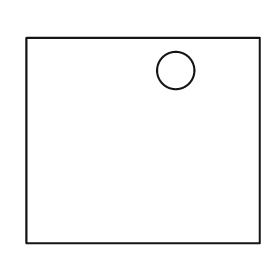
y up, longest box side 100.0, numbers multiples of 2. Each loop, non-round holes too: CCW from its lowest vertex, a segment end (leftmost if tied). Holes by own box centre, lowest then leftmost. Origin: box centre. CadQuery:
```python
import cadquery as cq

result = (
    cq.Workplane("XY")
    .moveTo(-50.0, -44.0)
    .lineTo(50.0, -44.0)
    .lineTo(50.0, 44.0)
    .lineTo(-50.0, 44.0)
    .close()
    .moveTo(14.0, 30.0)
    .circle(8.0)
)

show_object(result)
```